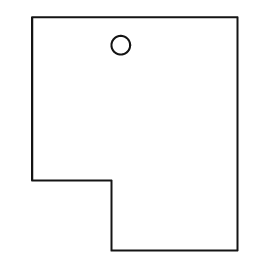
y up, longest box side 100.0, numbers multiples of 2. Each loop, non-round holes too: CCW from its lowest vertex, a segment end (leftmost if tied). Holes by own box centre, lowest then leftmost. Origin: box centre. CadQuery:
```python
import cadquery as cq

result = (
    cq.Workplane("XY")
    .moveTo(-10.0, -50.0)
    .lineTo(44.0, -50.0)
    .lineTo(44.0, 50.0)
    .lineTo(-44.0, 50.0)
    .lineTo(-44.0, -20.0)
    .lineTo(-10.0, -20.0)
    .close()
    .moveTo(-6.0, 38.0)
    .circle(4.0)
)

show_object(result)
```